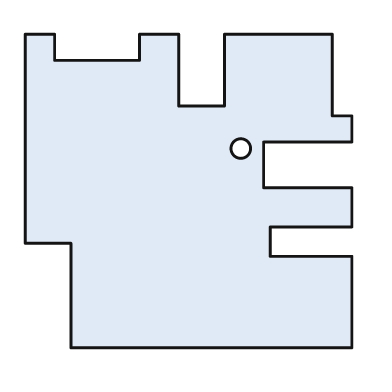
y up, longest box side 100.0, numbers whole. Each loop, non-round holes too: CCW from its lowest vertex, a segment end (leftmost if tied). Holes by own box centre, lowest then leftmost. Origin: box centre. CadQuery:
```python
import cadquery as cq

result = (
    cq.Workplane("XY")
    .moveTo(-36.0, -48.0)
    .lineTo(50.0, -48.0)
    .lineTo(50.0, -20.0)
    .lineTo(25.0, -20.0)
    .lineTo(25.0, -11.0)
    .lineTo(50.0, -11.0)
    .lineTo(50.0, 1.0)
    .lineTo(23.0, 1.0)
    .lineTo(23.0, 15.0)
    .lineTo(50.0, 15.0)
    .lineTo(50.0, 23.0)
    .lineTo(44.0, 23.0)
    .lineTo(44.0, 48.0)
    .lineTo(11.0, 48.0)
    .lineTo(11.0, 26.0)
    .lineTo(-3.0, 26.0)
    .lineTo(-3.0, 48.0)
    .lineTo(-15.0, 48.0)
    .lineTo(-15.0, 40.0)
    .lineTo(-41.0, 40.0)
    .lineTo(-41.0, 48.0)
    .lineTo(-50.0, 48.0)
    .lineTo(-50.0, -16.0)
    .lineTo(-36.0, -16.0)
    .close()
    .moveTo(16.0, 13.0)
    .circle(3.0)
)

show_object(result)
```